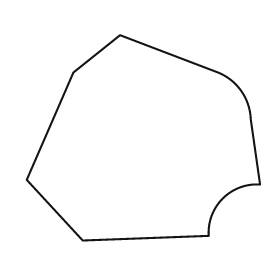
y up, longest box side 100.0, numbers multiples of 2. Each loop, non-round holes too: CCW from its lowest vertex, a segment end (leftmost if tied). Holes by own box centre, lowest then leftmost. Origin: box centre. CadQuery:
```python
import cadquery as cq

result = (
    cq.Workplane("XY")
    .moveTo(-26.0, -44.0)
    .lineTo(28.0, -42.0)
    .threePointArc((34.0, -26.0), (50.0, -20.0))
    .lineTo(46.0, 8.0)
    .threePointArc((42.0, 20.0), (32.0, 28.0))
    .lineTo(-10.0, 44.0)
    .lineTo(-30.0, 28.0)
    .lineTo(-50.0, -18.0)
    .close()
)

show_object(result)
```